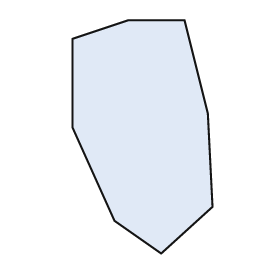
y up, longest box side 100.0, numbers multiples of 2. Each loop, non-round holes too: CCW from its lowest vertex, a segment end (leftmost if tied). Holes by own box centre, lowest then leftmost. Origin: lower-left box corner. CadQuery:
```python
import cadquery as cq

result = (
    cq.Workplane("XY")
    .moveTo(38.0, 0.0)
    .lineTo(60.0, 20.0)
    .lineTo(58.0, 60.0)
    .lineTo(48.0, 100.0)
    .lineTo(24.0, 100.0)
    .lineTo(0.0, 92.0)
    .lineTo(0.0, 54.0)
    .lineTo(18.0, 14.0)
    .close()
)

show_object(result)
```